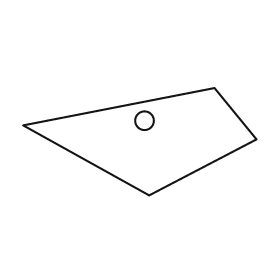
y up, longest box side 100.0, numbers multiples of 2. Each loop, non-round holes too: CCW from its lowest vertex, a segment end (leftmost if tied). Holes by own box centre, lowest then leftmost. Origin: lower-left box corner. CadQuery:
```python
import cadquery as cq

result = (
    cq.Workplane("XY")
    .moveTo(54.0, 0.0)
    .lineTo(100.0, 24.0)
    .lineTo(82.0, 46.0)
    .lineTo(0.0, 30.0)
    .close()
    .moveTo(52.0, 32.0)
    .circle(4.0)
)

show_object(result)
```